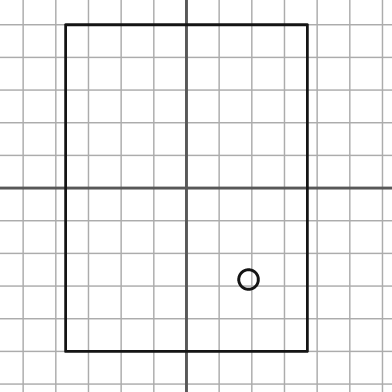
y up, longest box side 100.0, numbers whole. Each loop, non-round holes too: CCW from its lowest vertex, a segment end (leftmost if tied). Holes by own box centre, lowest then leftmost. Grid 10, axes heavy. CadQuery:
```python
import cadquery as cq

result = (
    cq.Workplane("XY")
    .moveTo(-37.0, -50.0)
    .lineTo(37.0, -50.0)
    .lineTo(37.0, 50.0)
    .lineTo(-37.0, 50.0)
    .close()
    .moveTo(19.0, -28.0)
    .circle(3.0)
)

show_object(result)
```